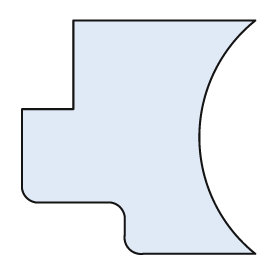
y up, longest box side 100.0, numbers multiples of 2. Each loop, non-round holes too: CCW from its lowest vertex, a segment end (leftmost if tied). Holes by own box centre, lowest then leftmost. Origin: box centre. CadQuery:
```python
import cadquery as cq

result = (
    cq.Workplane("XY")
    .moveTo(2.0, -50.0)
    .lineTo(50.0, -50.0)
    .threePointArc((26.0, 0.0), (50.0, 50.0))
    .lineTo(-28.0, 50.0)
    .lineTo(-28.0, 12.0)
    .lineTo(-50.0, 12.0)
    .lineTo(-50.0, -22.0)
    .threePointArc((-48.0, -26.0), (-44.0, -28.0))
    .lineTo(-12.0, -28.0)
    .threePointArc((-8.0, -30.0), (-6.0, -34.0))
    .lineTo(-6.0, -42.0)
    .threePointArc((-4.0, -48.0), (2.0, -50.0))
    .close()
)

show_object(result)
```